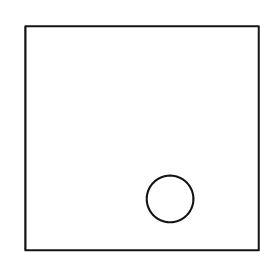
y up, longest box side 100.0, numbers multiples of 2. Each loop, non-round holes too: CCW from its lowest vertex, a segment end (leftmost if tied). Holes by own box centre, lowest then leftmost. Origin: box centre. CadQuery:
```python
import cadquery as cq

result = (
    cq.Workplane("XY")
    .moveTo(-50.0, -48.0)
    .lineTo(50.0, -48.0)
    .lineTo(50.0, 48.0)
    .lineTo(-50.0, 48.0)
    .close()
    .moveTo(12.0, -26.0)
    .circle(10.0)
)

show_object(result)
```